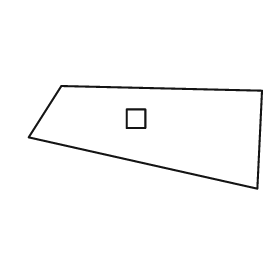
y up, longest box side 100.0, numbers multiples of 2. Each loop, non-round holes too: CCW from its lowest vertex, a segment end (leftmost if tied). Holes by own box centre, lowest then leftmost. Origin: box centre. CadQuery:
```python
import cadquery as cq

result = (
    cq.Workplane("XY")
    .moveTo(48.0, -22.0)
    .lineTo(50.0, 20.0)
    .lineTo(-36.0, 22.0)
    .lineTo(-50.0, 0.0)
    .close()
    .moveTo(-8.0, 4.0)
    .lineTo(0.0, 4.0)
    .lineTo(0.0, 12.0)
    .lineTo(-8.0, 12.0)
    .close()
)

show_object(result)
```